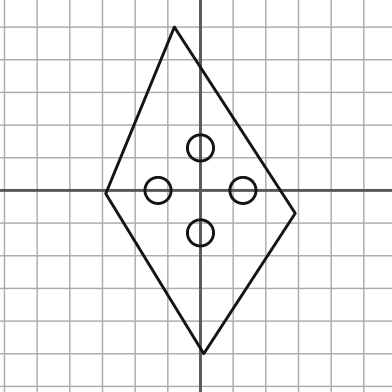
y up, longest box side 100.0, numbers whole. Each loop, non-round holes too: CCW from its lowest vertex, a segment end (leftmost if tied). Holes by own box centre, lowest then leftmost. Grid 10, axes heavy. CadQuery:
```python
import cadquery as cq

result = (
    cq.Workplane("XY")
    .moveTo(1.0, -50.0)
    .lineTo(29.0, -7.0)
    .lineTo(-8.0, 50.0)
    .lineTo(-29.0, -1.0)
    .close()
    .moveTo(0.0, -13.0)
    .circle(4.0)
    .moveTo(-13.0, 0.0)
    .circle(4.0)
    .moveTo(13.0, 0.0)
    .circle(4.0)
    .moveTo(0.0, 13.0)
    .circle(4.0)
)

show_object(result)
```